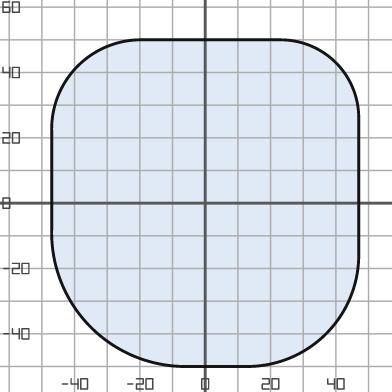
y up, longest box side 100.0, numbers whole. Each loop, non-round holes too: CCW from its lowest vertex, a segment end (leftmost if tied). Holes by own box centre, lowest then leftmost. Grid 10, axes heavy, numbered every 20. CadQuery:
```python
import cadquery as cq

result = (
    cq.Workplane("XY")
    .moveTo(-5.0, -50.0)
    .lineTo(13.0, -50.0)
    .threePointArc((37.0, -40.0), (47.0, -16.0))
    .lineTo(47.0, 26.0)
    .threePointArc((40.0, 43.0), (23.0, 50.0))
    .lineTo(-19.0, 50.0)
    .threePointArc((-39.0, 42.0), (-47.0, 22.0))
    .lineTo(-47.0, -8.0)
    .threePointArc((-35.0, -38.0), (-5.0, -50.0))
    .close()
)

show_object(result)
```